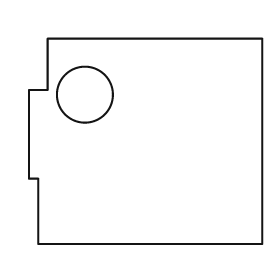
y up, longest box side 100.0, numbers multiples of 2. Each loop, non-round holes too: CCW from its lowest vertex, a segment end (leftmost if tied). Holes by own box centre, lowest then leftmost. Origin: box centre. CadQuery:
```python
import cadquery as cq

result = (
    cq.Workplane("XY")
    .moveTo(-46.0, -44.0)
    .lineTo(50.0, -44.0)
    .lineTo(50.0, 44.0)
    .lineTo(-42.0, 44.0)
    .lineTo(-42.0, 22.0)
    .lineTo(-50.0, 22.0)
    .lineTo(-50.0, -16.0)
    .lineTo(-46.0, -16.0)
    .close()
    .moveTo(-26.0, 20.0)
    .circle(12.0)
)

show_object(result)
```